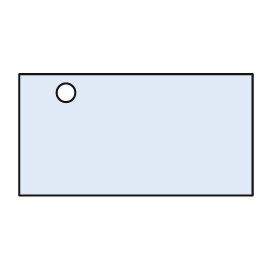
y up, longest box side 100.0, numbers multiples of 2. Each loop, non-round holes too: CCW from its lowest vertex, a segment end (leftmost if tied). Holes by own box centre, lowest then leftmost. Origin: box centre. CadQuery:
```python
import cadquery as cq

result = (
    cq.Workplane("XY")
    .moveTo(-50.0, -26.0)
    .lineTo(50.0, -26.0)
    .lineTo(50.0, 26.0)
    .lineTo(-50.0, 26.0)
    .close()
    .moveTo(-30.0, 18.0)
    .circle(4.0)
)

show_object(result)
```